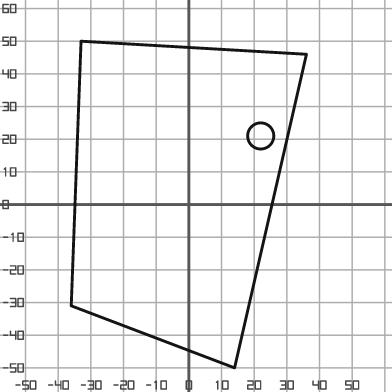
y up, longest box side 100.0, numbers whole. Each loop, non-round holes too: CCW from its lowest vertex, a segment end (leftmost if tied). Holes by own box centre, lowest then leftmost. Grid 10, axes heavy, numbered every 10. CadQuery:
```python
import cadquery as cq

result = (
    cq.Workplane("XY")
    .moveTo(14.0, -50.0)
    .lineTo(36.0, 46.0)
    .lineTo(-33.0, 50.0)
    .lineTo(-36.0, -31.0)
    .close()
    .moveTo(22.0, 21.0)
    .circle(4.0)
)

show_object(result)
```